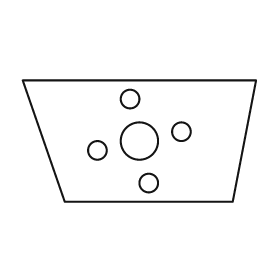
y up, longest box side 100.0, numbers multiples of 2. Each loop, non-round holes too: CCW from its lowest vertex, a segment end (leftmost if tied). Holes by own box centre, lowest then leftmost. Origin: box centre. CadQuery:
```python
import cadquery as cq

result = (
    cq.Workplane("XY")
    .moveTo(-32.0, -26.0)
    .lineTo(40.0, -26.0)
    .lineTo(50.0, 26.0)
    .lineTo(-50.0, 26.0)
    .close()
    .moveTo(4.0, -18.0)
    .circle(4.0)
    .moveTo(-18.0, -4.0)
    .circle(4.0)
    .moveTo(0.0, 0.0)
    .circle(8.0)
    .moveTo(18.0, 4.0)
    .circle(4.0)
    .moveTo(-4.0, 18.0)
    .circle(4.0)
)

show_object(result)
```